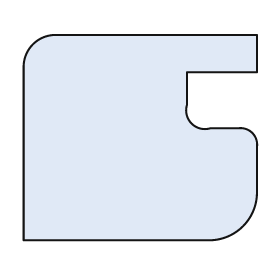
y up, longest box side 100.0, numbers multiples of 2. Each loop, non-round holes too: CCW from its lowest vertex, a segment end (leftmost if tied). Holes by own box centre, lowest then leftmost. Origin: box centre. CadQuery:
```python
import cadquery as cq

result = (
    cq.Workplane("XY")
    .moveTo(-50.0, -44.0)
    .lineTo(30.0, -44.0)
    .threePointArc((44.0, -38.0), (50.0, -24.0))
    .lineTo(50.0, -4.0)
    .threePointArc((48.0, 2.0), (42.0, 4.0))
    .lineTo(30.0, 4.0)
    .threePointArc((22.0, 6.0), (20.0, 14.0))
    .lineTo(20.0, 28.0)
    .lineTo(50.0, 28.0)
    .lineTo(50.0, 44.0)
    .lineTo(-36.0, 44.0)
    .threePointArc((-46.0, 40.0), (-50.0, 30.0))
    .close()
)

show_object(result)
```